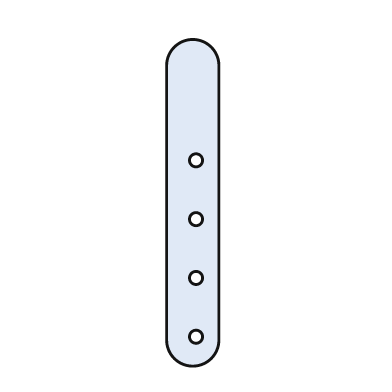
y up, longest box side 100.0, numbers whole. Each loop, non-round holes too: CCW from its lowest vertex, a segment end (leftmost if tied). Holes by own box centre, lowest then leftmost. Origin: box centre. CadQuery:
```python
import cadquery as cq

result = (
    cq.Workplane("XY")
    .moveTo(-8.0, -42.0)
    .threePointArc((0.0, -50.0), (8.0, -42.0))
    .lineTo(8.0, 42.0)
    .threePointArc((0.0, 50.0), (-8.0, 42.0))
    .close()
    .moveTo(1.0, -41.0)
    .circle(2.0)
    .moveTo(1.0, -23.0)
    .circle(2.0)
    .moveTo(1.0, -5.0)
    .circle(2.0)
    .moveTo(1.0, 13.0)
    .circle(2.0)
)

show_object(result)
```